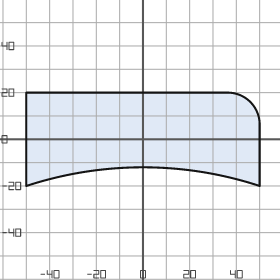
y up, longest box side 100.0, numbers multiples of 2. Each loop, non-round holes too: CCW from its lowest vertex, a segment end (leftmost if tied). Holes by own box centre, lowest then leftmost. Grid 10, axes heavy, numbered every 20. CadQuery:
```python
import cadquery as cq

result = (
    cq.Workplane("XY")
    .moveTo(-50.0, -20.0)
    .threePointArc((0.0, -12.0), (50.0, -20.0))
    .lineTo(50.0, 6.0)
    .threePointArc((46.0, 16.0), (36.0, 20.0))
    .lineTo(-50.0, 20.0)
    .close()
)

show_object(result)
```